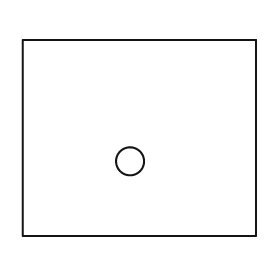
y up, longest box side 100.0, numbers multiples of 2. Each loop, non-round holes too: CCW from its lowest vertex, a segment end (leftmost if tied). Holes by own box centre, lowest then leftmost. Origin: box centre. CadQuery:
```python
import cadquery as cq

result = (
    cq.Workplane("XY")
    .moveTo(-50.0, -42.0)
    .lineTo(50.0, -42.0)
    .lineTo(50.0, 42.0)
    .lineTo(-50.0, 42.0)
    .close()
    .moveTo(-4.0, -10.0)
    .circle(6.0)
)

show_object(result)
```